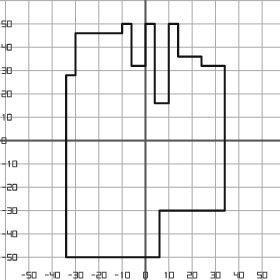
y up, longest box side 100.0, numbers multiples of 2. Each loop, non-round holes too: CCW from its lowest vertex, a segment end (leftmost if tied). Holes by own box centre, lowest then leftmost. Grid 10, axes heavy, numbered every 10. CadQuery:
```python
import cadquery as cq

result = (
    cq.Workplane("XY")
    .moveTo(-34.0, -50.0)
    .lineTo(6.0, -50.0)
    .lineTo(6.0, -30.0)
    .lineTo(34.0, -30.0)
    .lineTo(34.0, 32.0)
    .lineTo(24.0, 32.0)
    .lineTo(24.0, 36.0)
    .lineTo(14.0, 36.0)
    .lineTo(14.0, 50.0)
    .lineTo(10.0, 50.0)
    .lineTo(10.0, 16.0)
    .lineTo(4.0, 16.0)
    .lineTo(4.0, 50.0)
    .lineTo(0.0, 50.0)
    .lineTo(0.0, 32.0)
    .lineTo(-6.0, 32.0)
    .lineTo(-6.0, 50.0)
    .lineTo(-10.0, 50.0)
    .lineTo(-10.0, 46.0)
    .lineTo(-30.0, 46.0)
    .lineTo(-30.0, 28.0)
    .lineTo(-34.0, 28.0)
    .close()
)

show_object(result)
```